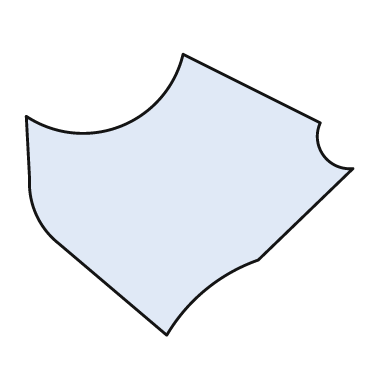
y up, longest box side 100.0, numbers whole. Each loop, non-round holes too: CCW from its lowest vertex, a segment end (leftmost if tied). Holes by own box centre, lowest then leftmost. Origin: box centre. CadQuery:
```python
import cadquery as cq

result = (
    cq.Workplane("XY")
    .moveTo(-7.0, -43.0)
    .threePointArc((5.0, -29.0), (21.0, -20.0))
    .lineTo(50.0, 8.0)
    .threePointArc((41.0, 12.0), (40.0, 22.0))
    .lineTo(-2.0, 43.0)
    .threePointArc((-21.0, 21.0), (-50.0, 24.0))
    .lineTo(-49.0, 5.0)
    .threePointArc((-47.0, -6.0), (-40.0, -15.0))
    .close()
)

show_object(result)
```